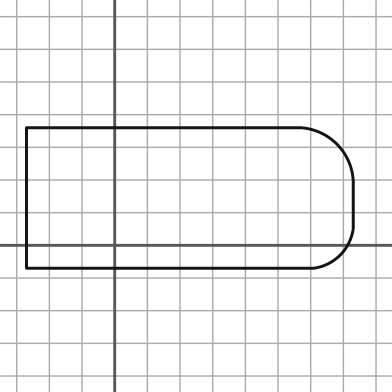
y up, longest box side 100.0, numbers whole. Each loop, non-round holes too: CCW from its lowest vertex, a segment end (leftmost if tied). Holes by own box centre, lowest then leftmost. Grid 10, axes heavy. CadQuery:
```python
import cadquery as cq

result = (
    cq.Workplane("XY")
    .moveTo(-27.0, -7.0)
    .lineTo(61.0, -7.0)
    .threePointArc((69.0, -3.0), (73.0, 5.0))
    .lineTo(73.0, 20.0)
    .threePointArc((68.0, 31.0), (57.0, 36.0))
    .lineTo(-27.0, 36.0)
    .close()
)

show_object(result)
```